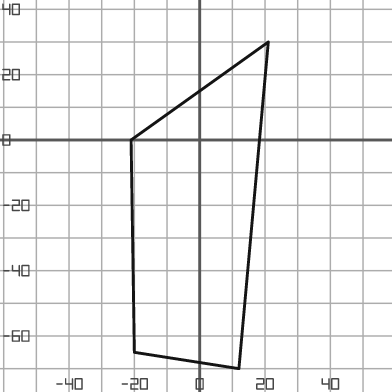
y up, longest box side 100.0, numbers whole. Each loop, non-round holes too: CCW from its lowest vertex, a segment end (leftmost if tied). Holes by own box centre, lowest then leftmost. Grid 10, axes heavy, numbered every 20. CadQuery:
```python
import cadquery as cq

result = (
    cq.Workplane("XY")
    .moveTo(12.0, -70.0)
    .lineTo(21.0, 30.0)
    .lineTo(-21.0, 0.0)
    .lineTo(-20.0, -65.0)
    .close()
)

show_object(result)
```